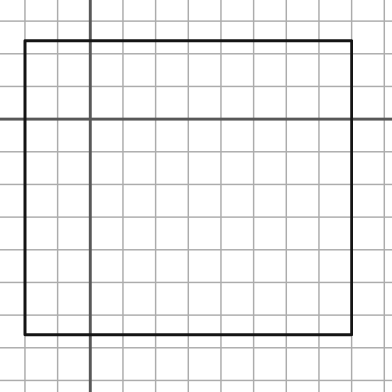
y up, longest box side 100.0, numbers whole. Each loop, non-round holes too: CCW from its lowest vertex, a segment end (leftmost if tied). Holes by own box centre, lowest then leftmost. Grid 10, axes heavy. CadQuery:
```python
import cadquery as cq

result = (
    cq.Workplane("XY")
    .moveTo(-20.0, -66.0)
    .lineTo(80.0, -66.0)
    .lineTo(80.0, 24.0)
    .lineTo(-20.0, 24.0)
    .close()
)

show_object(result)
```